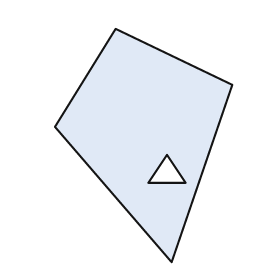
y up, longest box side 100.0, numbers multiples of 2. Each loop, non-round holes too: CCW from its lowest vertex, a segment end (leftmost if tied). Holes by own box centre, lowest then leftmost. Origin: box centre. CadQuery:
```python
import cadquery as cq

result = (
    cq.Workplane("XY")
    .moveTo(12.0, -50.0)
    .lineTo(38.0, 26.0)
    .lineTo(-12.0, 50.0)
    .lineTo(-38.0, 8.0)
    .close()
    .moveTo(2.0, -16.0)
    .lineTo(18.0, -16.0)
    .lineTo(10.0, -4.0)
    .close()
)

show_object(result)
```